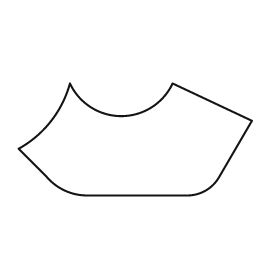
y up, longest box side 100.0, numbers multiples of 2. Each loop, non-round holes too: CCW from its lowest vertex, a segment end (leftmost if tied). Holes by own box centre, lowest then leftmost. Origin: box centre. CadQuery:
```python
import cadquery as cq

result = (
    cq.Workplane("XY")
    .moveTo(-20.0, -24.0)
    .lineTo(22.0, -24.0)
    .threePointArc((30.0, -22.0), (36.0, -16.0))
    .lineTo(50.0, 8.0)
    .lineTo(16.0, 24.0)
    .threePointArc((-6.0, 10.0), (-28.0, 24.0))
    .threePointArc((-36.0, 8.0), (-50.0, -4.0))
    .lineTo(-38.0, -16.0)
    .threePointArc((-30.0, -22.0), (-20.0, -24.0))
    .close()
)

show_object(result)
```